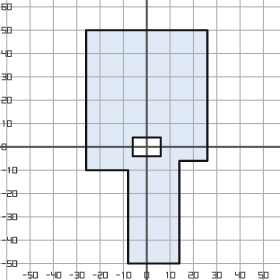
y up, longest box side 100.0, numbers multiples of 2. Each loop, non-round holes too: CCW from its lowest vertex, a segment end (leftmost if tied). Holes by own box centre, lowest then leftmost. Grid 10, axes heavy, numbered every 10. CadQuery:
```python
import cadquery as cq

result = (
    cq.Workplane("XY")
    .moveTo(-8.0, -50.0)
    .lineTo(14.0, -50.0)
    .lineTo(14.0, -6.0)
    .lineTo(26.0, -6.0)
    .lineTo(26.0, 50.0)
    .lineTo(-26.0, 50.0)
    .lineTo(-26.0, -10.0)
    .lineTo(-8.0, -10.0)
    .close()
    .moveTo(-6.0, -4.0)
    .lineTo(6.0, -4.0)
    .lineTo(6.0, 4.0)
    .lineTo(-6.0, 4.0)
    .close()
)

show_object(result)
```